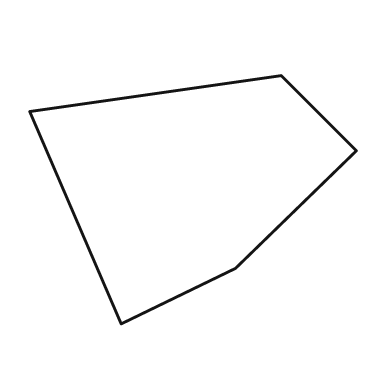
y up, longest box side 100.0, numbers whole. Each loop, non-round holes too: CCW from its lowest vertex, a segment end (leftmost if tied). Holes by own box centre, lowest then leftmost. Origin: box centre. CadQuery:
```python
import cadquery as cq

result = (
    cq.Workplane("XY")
    .moveTo(-22.0, -38.0)
    .lineTo(13.0, -21.0)
    .lineTo(50.0, 15.0)
    .lineTo(27.0, 38.0)
    .lineTo(-50.0, 27.0)
    .close()
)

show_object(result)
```